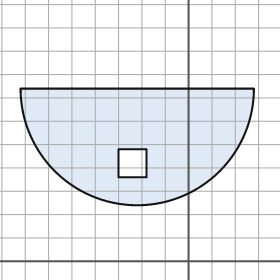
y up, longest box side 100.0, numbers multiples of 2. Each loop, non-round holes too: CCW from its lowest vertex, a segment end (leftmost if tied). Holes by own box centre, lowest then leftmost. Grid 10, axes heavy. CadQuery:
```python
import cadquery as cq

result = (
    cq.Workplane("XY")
    .moveTo(-72.0, 74.0)
    .threePointArc((-22.0, 24.0), (28.0, 74.0))
    .close()
    .moveTo(-30.0, 36.0)
    .lineTo(-18.0, 36.0)
    .lineTo(-18.0, 48.0)
    .lineTo(-30.0, 48.0)
    .close()
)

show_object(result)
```